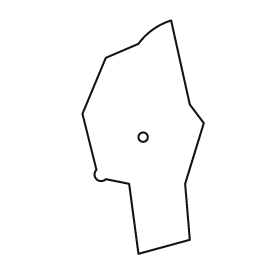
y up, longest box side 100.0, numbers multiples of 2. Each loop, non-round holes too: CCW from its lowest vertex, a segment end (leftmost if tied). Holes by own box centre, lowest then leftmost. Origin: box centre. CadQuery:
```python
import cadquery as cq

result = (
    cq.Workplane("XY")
    .moveTo(-2.0, -50.0)
    .lineTo(20.0, -44.0)
    .lineTo(18.0, -20.0)
    .lineTo(26.0, 6.0)
    .lineTo(20.0, 14.0)
    .lineTo(12.0, 50.0)
    .threePointArc((4.0, 46.0), (-2.0, 40.0))
    .lineTo(-16.0, 34.0)
    .lineTo(-26.0, 10.0)
    .lineTo(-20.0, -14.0)
    .threePointArc((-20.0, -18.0), (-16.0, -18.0))
    .lineTo(-6.0, -20.0)
    .close()
    .moveTo(0.0, 0.0)
    .circle(2.0)
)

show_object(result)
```